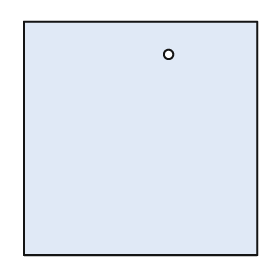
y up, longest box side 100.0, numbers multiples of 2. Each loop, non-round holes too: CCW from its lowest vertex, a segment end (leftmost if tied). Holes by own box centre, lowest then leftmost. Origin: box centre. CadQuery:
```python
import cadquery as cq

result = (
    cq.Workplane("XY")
    .moveTo(-50.0, -50.0)
    .lineTo(50.0, -50.0)
    .lineTo(50.0, 50.0)
    .lineTo(-50.0, 50.0)
    .close()
    .moveTo(12.0, 36.0)
    .circle(2.0)
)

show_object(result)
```